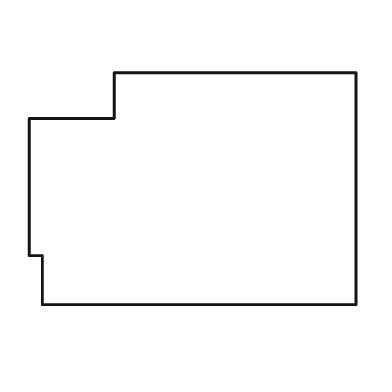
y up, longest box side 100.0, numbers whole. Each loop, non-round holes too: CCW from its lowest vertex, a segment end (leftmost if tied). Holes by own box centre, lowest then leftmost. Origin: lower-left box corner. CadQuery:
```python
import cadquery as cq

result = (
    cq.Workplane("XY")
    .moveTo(4.0, 0.0)
    .lineTo(100.0, 0.0)
    .lineTo(100.0, 71.0)
    .lineTo(26.0, 71.0)
    .lineTo(26.0, 57.0)
    .lineTo(0.0, 57.0)
    .lineTo(0.0, 15.0)
    .lineTo(4.0, 15.0)
    .close()
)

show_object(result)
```